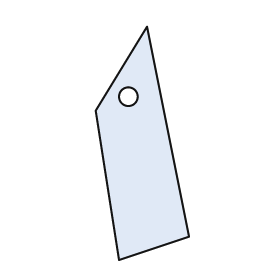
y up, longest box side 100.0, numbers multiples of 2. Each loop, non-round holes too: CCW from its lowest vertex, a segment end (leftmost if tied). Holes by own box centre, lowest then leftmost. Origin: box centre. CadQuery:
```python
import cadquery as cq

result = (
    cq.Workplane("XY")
    .moveTo(-10.0, -50.0)
    .lineTo(20.0, -40.0)
    .lineTo(2.0, 50.0)
    .lineTo(-20.0, 14.0)
    .close()
    .moveTo(-6.0, 20.0)
    .circle(4.0)
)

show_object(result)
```